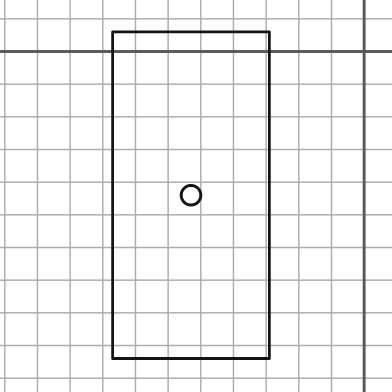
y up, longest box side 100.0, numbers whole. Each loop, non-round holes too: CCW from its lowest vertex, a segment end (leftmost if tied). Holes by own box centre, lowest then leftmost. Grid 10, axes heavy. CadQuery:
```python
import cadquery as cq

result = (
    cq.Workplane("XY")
    .moveTo(-77.0, -94.0)
    .lineTo(-29.0, -94.0)
    .lineTo(-29.0, 6.0)
    .lineTo(-77.0, 6.0)
    .close()
    .moveTo(-53.0, -44.0)
    .circle(3.0)
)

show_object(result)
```